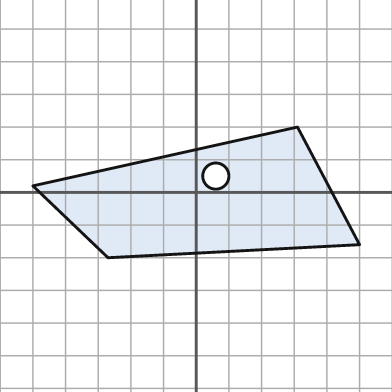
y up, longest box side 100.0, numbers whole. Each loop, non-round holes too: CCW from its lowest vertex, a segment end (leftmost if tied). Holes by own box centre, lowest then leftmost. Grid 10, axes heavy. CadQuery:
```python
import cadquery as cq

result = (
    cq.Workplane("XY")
    .moveTo(-27.0, -20.0)
    .lineTo(50.0, -16.0)
    .lineTo(31.0, 20.0)
    .lineTo(-50.0, 2.0)
    .close()
    .moveTo(6.0, 5.0)
    .circle(4.0)
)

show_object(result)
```